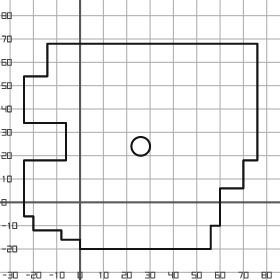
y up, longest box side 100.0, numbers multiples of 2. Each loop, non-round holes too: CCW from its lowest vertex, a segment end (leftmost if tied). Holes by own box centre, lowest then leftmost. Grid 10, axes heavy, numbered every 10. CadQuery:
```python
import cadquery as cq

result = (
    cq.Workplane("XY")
    .moveTo(0.0, -20.0)
    .lineTo(56.0, -20.0)
    .lineTo(56.0, -10.0)
    .lineTo(60.0, -10.0)
    .lineTo(60.0, 6.0)
    .lineTo(70.0, 6.0)
    .lineTo(70.0, 18.0)
    .lineTo(76.0, 18.0)
    .lineTo(76.0, 68.0)
    .lineTo(-14.0, 68.0)
    .lineTo(-14.0, 54.0)
    .lineTo(-24.0, 54.0)
    .lineTo(-24.0, 34.0)
    .lineTo(-6.0, 34.0)
    .lineTo(-6.0, 18.0)
    .lineTo(-24.0, 18.0)
    .lineTo(-24.0, -6.0)
    .lineTo(-20.0, -6.0)
    .lineTo(-20.0, -12.0)
    .lineTo(-8.0, -12.0)
    .lineTo(-8.0, -16.0)
    .lineTo(0.0, -16.0)
    .close()
    .moveTo(26.0, 24.0)
    .circle(4.0)
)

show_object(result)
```